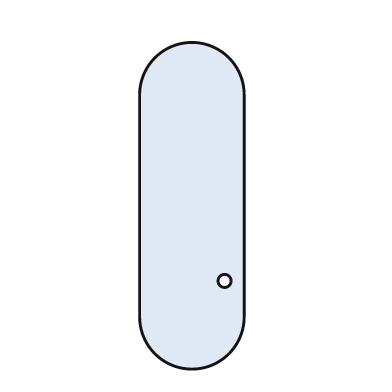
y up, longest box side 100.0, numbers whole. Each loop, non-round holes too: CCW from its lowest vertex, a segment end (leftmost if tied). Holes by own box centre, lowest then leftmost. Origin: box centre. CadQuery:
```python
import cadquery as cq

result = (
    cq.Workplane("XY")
    .moveTo(-16.0, -34.0)
    .threePointArc((0.0, -50.0), (16.0, -34.0))
    .lineTo(16.0, 34.0)
    .threePointArc((0.0, 50.0), (-16.0, 34.0))
    .close()
    .moveTo(10.0, -23.0)
    .circle(2.0)
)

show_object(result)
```